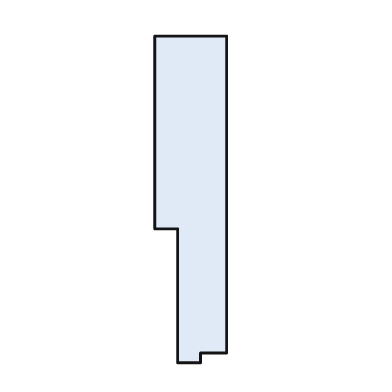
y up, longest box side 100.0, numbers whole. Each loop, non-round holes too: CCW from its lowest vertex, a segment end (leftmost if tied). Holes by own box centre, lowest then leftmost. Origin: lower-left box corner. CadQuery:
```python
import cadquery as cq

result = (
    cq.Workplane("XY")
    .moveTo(7.0, 0.0)
    .lineTo(14.0, 0.0)
    .lineTo(14.0, 3.0)
    .lineTo(22.0, 3.0)
    .lineTo(22.0, 100.0)
    .lineTo(0.0, 100.0)
    .lineTo(0.0, 41.0)
    .lineTo(7.0, 41.0)
    .close()
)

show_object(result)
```